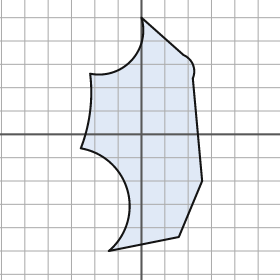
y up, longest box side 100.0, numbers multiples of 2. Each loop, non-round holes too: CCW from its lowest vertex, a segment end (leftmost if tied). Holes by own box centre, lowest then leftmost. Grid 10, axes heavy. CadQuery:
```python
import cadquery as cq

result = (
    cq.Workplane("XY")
    .moveTo(-14.0, -50.0)
    .lineTo(16.0, -44.0)
    .lineTo(26.0, -20.0)
    .lineTo(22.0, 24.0)
    .threePointArc((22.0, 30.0), (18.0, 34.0))
    .lineTo(0.0, 50.0)
    .threePointArc((-4.0, 32.0), (-22.0, 26.0))
    .threePointArc((-22.0, 10.0), (-26.0, -6.0))
    .threePointArc((-6.0, -24.0), (-14.0, -50.0))
    .close()
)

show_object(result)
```